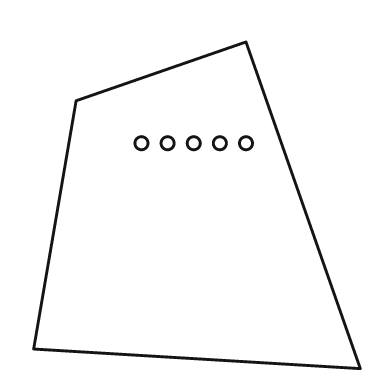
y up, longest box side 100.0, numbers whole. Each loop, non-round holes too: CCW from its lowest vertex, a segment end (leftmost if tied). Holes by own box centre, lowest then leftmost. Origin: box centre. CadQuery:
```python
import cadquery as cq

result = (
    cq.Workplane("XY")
    .moveTo(50.0, -50.0)
    .lineTo(15.0, 50.0)
    .lineTo(-37.0, 32.0)
    .lineTo(-50.0, -44.0)
    .close()
    .moveTo(-17.0, 19.0)
    .circle(2.0)
    .moveTo(-9.0, 19.0)
    .circle(2.0)
    .moveTo(-1.0, 19.0)
    .circle(2.0)
    .moveTo(7.0, 19.0)
    .circle(2.0)
    .moveTo(15.0, 19.0)
    .circle(2.0)
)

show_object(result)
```